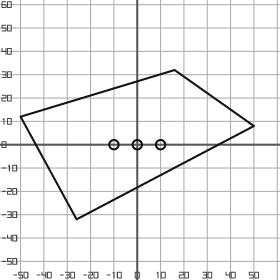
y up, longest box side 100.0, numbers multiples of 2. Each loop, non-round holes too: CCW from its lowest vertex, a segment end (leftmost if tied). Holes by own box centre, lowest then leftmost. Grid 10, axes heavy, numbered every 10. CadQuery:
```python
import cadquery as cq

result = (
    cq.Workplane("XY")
    .moveTo(-26.0, -32.0)
    .lineTo(50.0, 8.0)
    .lineTo(16.0, 32.0)
    .lineTo(-50.0, 12.0)
    .close()
    .moveTo(-10.0, 0.0)
    .circle(2.0)
    .moveTo(0.0, 0.0)
    .circle(2.0)
    .moveTo(10.0, 0.0)
    .circle(2.0)
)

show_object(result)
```